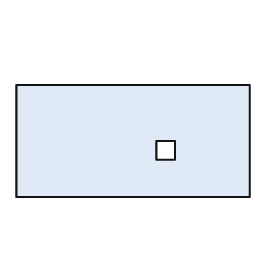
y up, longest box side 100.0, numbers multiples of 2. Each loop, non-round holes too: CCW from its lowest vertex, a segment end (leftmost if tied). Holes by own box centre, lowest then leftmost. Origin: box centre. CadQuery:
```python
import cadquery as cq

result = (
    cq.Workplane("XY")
    .moveTo(-50.0, -24.0)
    .lineTo(50.0, -24.0)
    .lineTo(50.0, 24.0)
    .lineTo(-50.0, 24.0)
    .close()
    .moveTo(10.0, -8.0)
    .lineTo(18.0, -8.0)
    .lineTo(18.0, 0.0)
    .lineTo(10.0, 0.0)
    .close()
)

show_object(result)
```